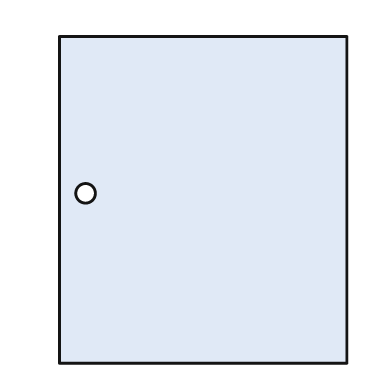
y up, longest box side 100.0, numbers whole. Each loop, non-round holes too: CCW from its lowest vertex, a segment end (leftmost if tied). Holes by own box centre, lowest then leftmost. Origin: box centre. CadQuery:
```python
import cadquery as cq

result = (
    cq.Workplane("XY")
    .moveTo(-44.0, -50.0)
    .lineTo(44.0, -50.0)
    .lineTo(44.0, 50.0)
    .lineTo(-44.0, 50.0)
    .close()
    .moveTo(-36.0, 2.0)
    .circle(3.0)
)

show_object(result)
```